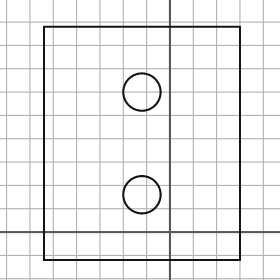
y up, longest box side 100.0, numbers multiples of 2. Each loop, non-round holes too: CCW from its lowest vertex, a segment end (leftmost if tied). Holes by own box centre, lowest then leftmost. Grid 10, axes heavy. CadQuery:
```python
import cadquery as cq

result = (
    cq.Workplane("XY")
    .moveTo(-54.0, -12.0)
    .lineTo(30.0, -12.0)
    .lineTo(30.0, 88.0)
    .lineTo(-54.0, 88.0)
    .close()
    .moveTo(-12.0, 16.0)
    .circle(8.0)
    .moveTo(-12.0, 60.0)
    .circle(8.0)
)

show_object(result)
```